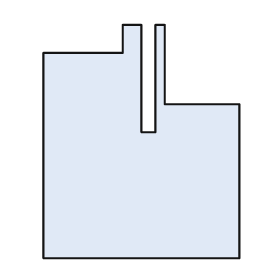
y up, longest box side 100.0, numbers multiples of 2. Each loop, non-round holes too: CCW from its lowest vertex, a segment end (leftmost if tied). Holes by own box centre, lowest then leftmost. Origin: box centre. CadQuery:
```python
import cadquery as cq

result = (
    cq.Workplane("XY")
    .moveTo(-42.0, -50.0)
    .lineTo(42.0, -50.0)
    .lineTo(42.0, 16.0)
    .lineTo(10.0, 16.0)
    .lineTo(10.0, 50.0)
    .lineTo(6.0, 50.0)
    .lineTo(6.0, 4.0)
    .lineTo(0.0, 4.0)
    .lineTo(0.0, 50.0)
    .lineTo(-8.0, 50.0)
    .lineTo(-8.0, 38.0)
    .lineTo(-42.0, 38.0)
    .close()
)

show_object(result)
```